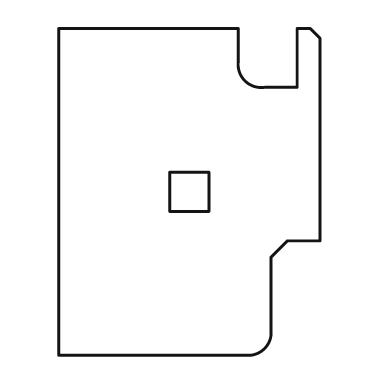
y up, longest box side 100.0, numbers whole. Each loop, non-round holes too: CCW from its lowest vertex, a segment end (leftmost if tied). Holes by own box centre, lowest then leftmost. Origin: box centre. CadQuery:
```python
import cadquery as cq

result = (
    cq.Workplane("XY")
    .moveTo(-40.0, -50.0)
    .lineTo(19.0, -50.0)
    .threePointArc((23.0, -48.0), (25.0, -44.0))
    .lineTo(25.0, -20.0)
    .lineTo(30.0, -15.0)
    .lineTo(40.0, -15.0)
    .lineTo(40.0, 47.0)
    .lineTo(37.0, 50.0)
    .lineTo(33.0, 50.0)
    .lineTo(33.0, 32.0)
    .lineTo(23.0, 32.0)
    .threePointArc((17.0, 34.0), (15.0, 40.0))
    .lineTo(15.0, 50.0)
    .lineTo(-40.0, 50.0)
    .close()
    .moveTo(-6.0, -6.0)
    .lineTo(6.0, -6.0)
    .lineTo(6.0, 6.0)
    .lineTo(-6.0, 6.0)
    .close()
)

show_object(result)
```